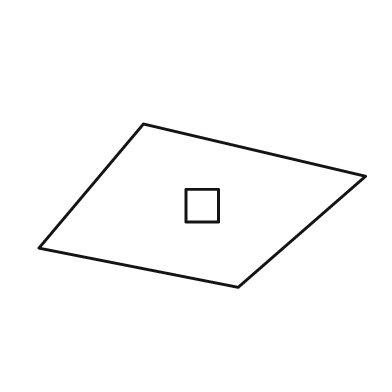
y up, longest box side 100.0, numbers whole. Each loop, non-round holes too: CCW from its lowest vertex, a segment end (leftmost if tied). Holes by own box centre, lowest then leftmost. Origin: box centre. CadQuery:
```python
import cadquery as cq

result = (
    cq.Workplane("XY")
    .moveTo(11.0, -25.0)
    .lineTo(50.0, 9.0)
    .lineTo(-18.0, 25.0)
    .lineTo(-50.0, -13.0)
    .close()
    .moveTo(-5.0, -5.0)
    .lineTo(5.0, -5.0)
    .lineTo(5.0, 5.0)
    .lineTo(-5.0, 5.0)
    .close()
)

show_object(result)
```